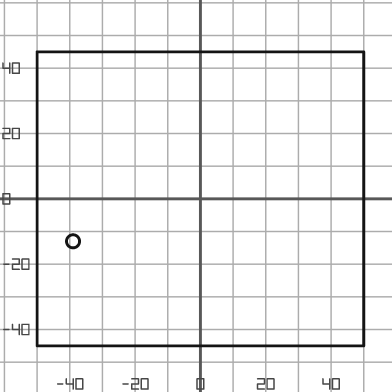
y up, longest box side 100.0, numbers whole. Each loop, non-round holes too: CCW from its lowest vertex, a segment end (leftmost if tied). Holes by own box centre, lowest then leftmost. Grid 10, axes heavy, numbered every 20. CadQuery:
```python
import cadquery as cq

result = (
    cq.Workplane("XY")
    .moveTo(-50.0, -45.0)
    .lineTo(50.0, -45.0)
    .lineTo(50.0, 45.0)
    .lineTo(-50.0, 45.0)
    .close()
    .moveTo(-39.0, -13.0)
    .circle(2.0)
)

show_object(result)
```